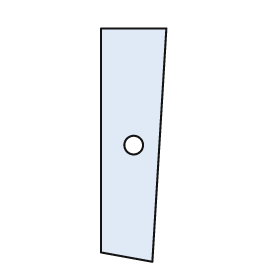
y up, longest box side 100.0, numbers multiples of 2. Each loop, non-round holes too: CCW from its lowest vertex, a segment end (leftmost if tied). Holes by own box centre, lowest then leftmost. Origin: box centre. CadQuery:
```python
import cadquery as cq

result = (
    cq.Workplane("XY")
    .moveTo(8.0, -50.0)
    .lineTo(14.0, 50.0)
    .lineTo(-14.0, 50.0)
    .lineTo(-14.0, -46.0)
    .close()
    .moveTo(0.0, 0.0)
    .circle(4.0)
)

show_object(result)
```